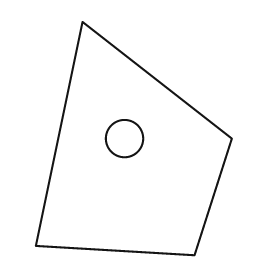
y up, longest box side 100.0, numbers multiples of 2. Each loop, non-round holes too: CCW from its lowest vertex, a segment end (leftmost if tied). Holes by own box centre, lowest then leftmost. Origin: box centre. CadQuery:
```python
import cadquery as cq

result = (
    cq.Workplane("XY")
    .moveTo(26.0, -50.0)
    .lineTo(42.0, 0.0)
    .lineTo(-22.0, 50.0)
    .lineTo(-42.0, -46.0)
    .close()
    .moveTo(-4.0, 0.0)
    .circle(8.0)
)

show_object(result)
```